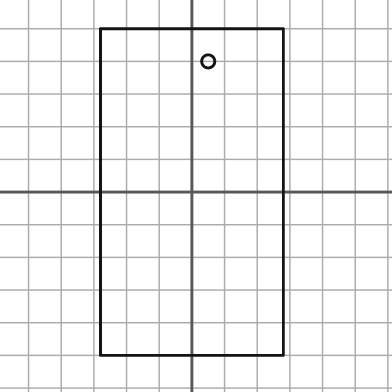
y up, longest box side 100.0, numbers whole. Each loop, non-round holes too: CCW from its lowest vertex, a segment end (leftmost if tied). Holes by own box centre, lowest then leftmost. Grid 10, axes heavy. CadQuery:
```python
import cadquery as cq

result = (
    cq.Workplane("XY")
    .moveTo(-28.0, -50.0)
    .lineTo(28.0, -50.0)
    .lineTo(28.0, 50.0)
    .lineTo(-28.0, 50.0)
    .close()
    .moveTo(5.0, 40.0)
    .circle(2.0)
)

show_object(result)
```